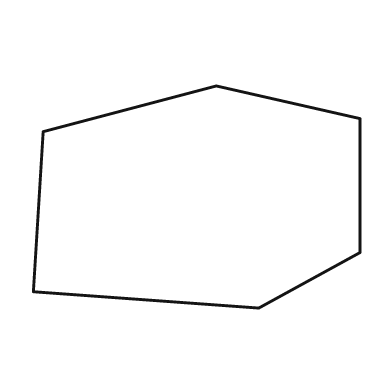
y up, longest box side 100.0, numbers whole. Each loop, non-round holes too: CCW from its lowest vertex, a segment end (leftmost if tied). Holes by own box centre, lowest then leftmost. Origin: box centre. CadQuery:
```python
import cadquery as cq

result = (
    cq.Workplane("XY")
    .moveTo(19.0, -34.0)
    .lineTo(50.0, -17.0)
    .lineTo(50.0, 24.0)
    .lineTo(6.0, 34.0)
    .lineTo(-47.0, 20.0)
    .lineTo(-50.0, -29.0)
    .close()
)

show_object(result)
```